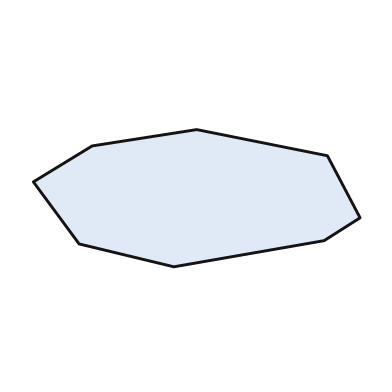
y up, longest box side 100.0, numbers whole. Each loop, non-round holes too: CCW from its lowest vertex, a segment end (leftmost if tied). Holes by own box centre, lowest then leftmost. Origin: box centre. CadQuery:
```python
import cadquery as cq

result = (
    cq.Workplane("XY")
    .moveTo(-7.0, -21.0)
    .lineTo(39.0, -13.0)
    .lineTo(50.0, -6.0)
    .lineTo(40.0, 13.0)
    .lineTo(0.0, 21.0)
    .lineTo(-32.0, 16.0)
    .lineTo(-50.0, 5.0)
    .lineTo(-36.0, -14.0)
    .close()
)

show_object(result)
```